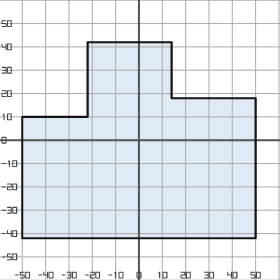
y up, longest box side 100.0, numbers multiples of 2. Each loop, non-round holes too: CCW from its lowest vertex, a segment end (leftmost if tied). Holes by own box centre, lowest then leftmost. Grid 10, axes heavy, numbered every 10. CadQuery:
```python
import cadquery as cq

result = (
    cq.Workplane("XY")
    .moveTo(-50.0, -42.0)
    .lineTo(50.0, -42.0)
    .lineTo(50.0, 18.0)
    .lineTo(14.0, 18.0)
    .lineTo(14.0, 42.0)
    .lineTo(-22.0, 42.0)
    .lineTo(-22.0, 10.0)
    .lineTo(-50.0, 10.0)
    .close()
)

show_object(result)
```